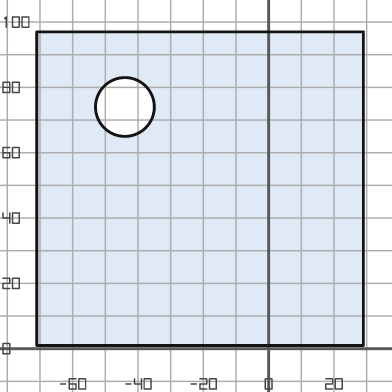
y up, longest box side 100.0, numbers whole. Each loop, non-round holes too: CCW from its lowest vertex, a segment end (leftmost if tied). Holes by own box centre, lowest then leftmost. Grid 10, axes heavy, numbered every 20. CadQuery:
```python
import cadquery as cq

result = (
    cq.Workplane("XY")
    .moveTo(-71.0, 1.0)
    .lineTo(29.0, 1.0)
    .lineTo(29.0, 97.0)
    .lineTo(-71.0, 97.0)
    .close()
    .moveTo(-44.0, 74.0)
    .circle(9.0)
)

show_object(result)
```